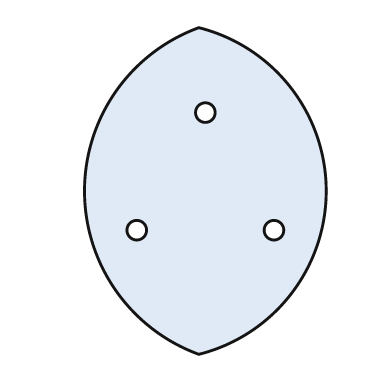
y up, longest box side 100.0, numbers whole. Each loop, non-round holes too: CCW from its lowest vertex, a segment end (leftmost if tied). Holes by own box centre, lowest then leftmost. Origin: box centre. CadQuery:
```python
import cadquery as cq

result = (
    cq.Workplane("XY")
    .moveTo(-2.0, -50.0)
    .threePointArc((37.0, 0.0), (-2.0, 50.0))
    .threePointArc((-37.0, 0.0), (-2.0, -50.0))
    .close()
    .moveTo(-21.0, -12.0)
    .circle(3.0)
    .moveTo(21.0, -12.0)
    .circle(3.0)
    .moveTo(0.0, 24.0)
    .circle(3.0)
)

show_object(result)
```